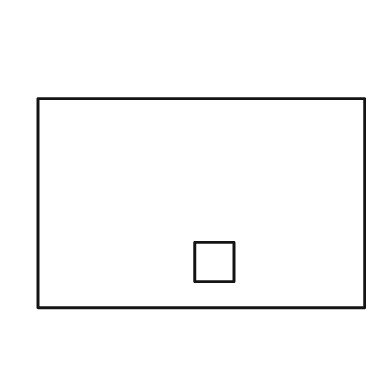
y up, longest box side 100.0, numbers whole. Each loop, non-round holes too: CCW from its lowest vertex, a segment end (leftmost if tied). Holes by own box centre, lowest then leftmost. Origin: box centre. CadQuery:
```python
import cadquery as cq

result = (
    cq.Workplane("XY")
    .moveTo(-50.0, -32.0)
    .lineTo(50.0, -32.0)
    .lineTo(50.0, 32.0)
    .lineTo(-50.0, 32.0)
    .close()
    .moveTo(-2.0, -24.0)
    .lineTo(10.0, -24.0)
    .lineTo(10.0, -12.0)
    .lineTo(-2.0, -12.0)
    .close()
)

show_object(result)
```